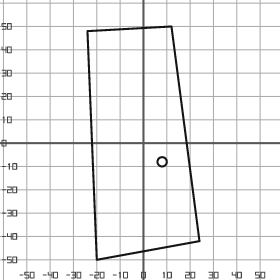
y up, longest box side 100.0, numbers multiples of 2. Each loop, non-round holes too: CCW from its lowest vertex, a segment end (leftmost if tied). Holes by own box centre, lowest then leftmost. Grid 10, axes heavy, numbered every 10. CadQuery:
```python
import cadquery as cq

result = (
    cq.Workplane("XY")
    .moveTo(-20.0, -50.0)
    .lineTo(24.0, -42.0)
    .lineTo(12.0, 50.0)
    .lineTo(-24.0, 48.0)
    .close()
    .moveTo(8.0, -8.0)
    .circle(2.0)
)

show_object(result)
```